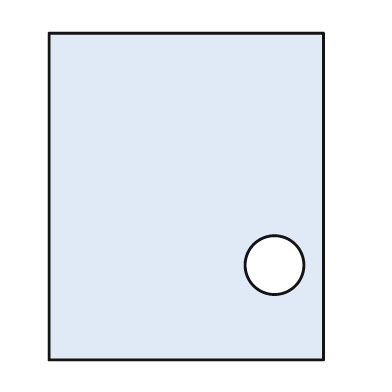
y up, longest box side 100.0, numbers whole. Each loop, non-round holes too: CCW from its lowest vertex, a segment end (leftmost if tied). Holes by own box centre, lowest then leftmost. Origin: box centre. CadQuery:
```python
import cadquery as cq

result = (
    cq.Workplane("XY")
    .moveTo(-42.0, -50.0)
    .lineTo(42.0, -50.0)
    .lineTo(42.0, 50.0)
    .lineTo(-42.0, 50.0)
    .close()
    .moveTo(27.0, -21.0)
    .circle(9.0)
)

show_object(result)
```